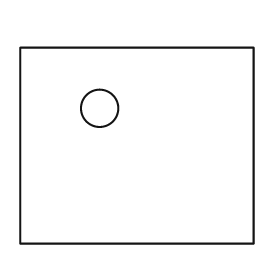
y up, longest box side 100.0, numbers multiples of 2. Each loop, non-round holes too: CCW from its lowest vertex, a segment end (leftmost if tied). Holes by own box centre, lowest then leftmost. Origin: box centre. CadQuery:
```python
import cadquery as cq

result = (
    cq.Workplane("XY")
    .moveTo(-50.0, -42.0)
    .lineTo(50.0, -42.0)
    .lineTo(50.0, 42.0)
    .lineTo(-50.0, 42.0)
    .close()
    .moveTo(-16.0, 16.0)
    .circle(8.0)
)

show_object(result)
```